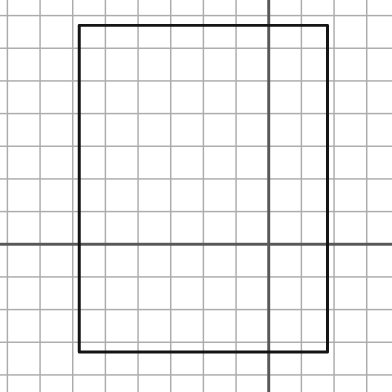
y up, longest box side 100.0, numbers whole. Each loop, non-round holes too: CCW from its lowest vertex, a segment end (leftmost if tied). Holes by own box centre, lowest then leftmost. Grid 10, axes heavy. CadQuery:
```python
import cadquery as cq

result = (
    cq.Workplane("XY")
    .moveTo(-58.0, -33.0)
    .lineTo(18.0, -33.0)
    .lineTo(18.0, 67.0)
    .lineTo(-58.0, 67.0)
    .close()
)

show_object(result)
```